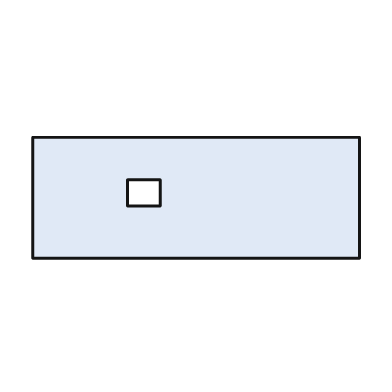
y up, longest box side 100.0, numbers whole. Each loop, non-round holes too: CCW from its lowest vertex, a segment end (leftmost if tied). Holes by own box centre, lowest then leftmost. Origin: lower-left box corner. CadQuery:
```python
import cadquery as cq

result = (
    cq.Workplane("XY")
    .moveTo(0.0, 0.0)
    .lineTo(100.0, 0.0)
    .lineTo(100.0, 37.0)
    .lineTo(0.0, 37.0)
    .close()
    .moveTo(29.0, 16.0)
    .lineTo(39.0, 16.0)
    .lineTo(39.0, 24.0)
    .lineTo(29.0, 24.0)
    .close()
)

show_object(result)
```